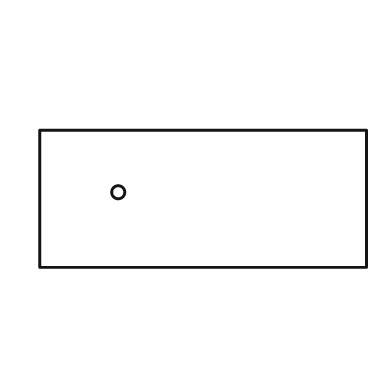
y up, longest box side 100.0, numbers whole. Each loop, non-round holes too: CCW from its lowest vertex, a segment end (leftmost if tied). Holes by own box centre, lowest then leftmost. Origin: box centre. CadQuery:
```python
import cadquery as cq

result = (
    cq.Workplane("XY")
    .moveTo(-50.0, -21.0)
    .lineTo(50.0, -21.0)
    .lineTo(50.0, 21.0)
    .lineTo(-50.0, 21.0)
    .close()
    .moveTo(-26.0, 2.0)
    .circle(2.0)
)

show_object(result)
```